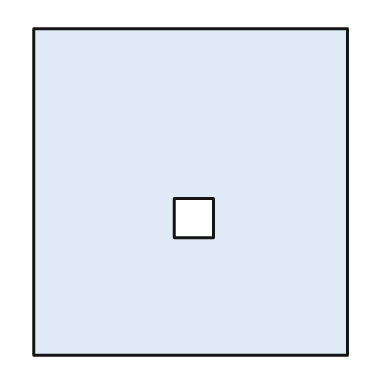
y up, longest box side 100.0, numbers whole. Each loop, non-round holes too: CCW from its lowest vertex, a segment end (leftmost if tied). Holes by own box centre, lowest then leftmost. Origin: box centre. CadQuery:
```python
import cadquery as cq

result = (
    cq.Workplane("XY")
    .moveTo(-48.0, -50.0)
    .lineTo(48.0, -50.0)
    .lineTo(48.0, 50.0)
    .lineTo(-48.0, 50.0)
    .close()
    .moveTo(-5.0, -14.0)
    .lineTo(7.0, -14.0)
    .lineTo(7.0, -2.0)
    .lineTo(-5.0, -2.0)
    .close()
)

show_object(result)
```